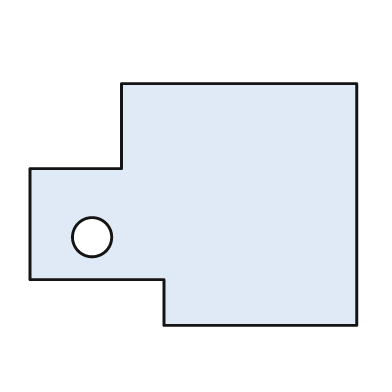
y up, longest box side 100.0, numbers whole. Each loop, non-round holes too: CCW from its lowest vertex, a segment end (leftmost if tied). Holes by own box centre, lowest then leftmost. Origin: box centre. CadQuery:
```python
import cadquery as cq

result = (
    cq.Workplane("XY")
    .moveTo(-9.0, -37.0)
    .lineTo(50.0, -37.0)
    .lineTo(50.0, 37.0)
    .lineTo(-22.0, 37.0)
    .lineTo(-22.0, 11.0)
    .lineTo(-50.0, 11.0)
    .lineTo(-50.0, -23.0)
    .lineTo(-9.0, -23.0)
    .close()
    .moveTo(-31.0, -10.0)
    .circle(6.0)
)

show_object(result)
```